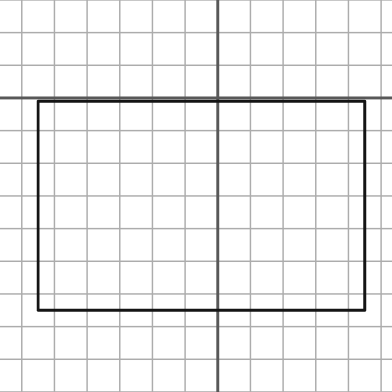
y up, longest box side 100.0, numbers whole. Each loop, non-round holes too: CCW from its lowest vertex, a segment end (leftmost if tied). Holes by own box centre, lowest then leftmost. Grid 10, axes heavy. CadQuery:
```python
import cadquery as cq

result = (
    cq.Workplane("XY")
    .moveTo(-55.0, -65.0)
    .lineTo(45.0, -65.0)
    .lineTo(45.0, -1.0)
    .lineTo(-55.0, -1.0)
    .close()
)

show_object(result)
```